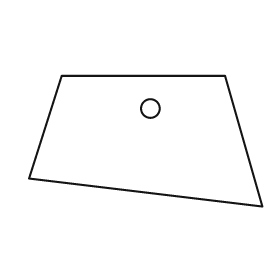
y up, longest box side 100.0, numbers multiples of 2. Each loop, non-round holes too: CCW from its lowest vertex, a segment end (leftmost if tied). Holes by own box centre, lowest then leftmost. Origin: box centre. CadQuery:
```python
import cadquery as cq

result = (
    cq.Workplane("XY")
    .moveTo(50.0, -28.0)
    .lineTo(34.0, 28.0)
    .lineTo(-36.0, 28.0)
    .lineTo(-50.0, -16.0)
    .close()
    .moveTo(2.0, 14.0)
    .circle(4.0)
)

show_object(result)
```